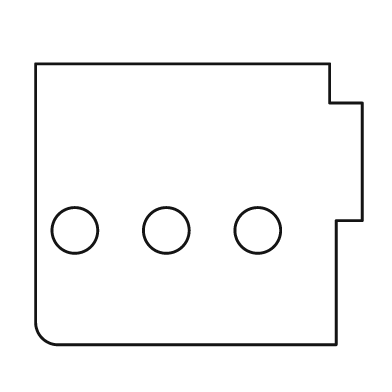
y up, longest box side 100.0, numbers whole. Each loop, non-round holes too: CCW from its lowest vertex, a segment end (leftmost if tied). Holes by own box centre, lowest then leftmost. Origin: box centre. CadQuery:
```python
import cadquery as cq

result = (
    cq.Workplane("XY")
    .moveTo(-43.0, -43.0)
    .lineTo(42.0, -43.0)
    .lineTo(42.0, -5.0)
    .lineTo(50.0, -5.0)
    .lineTo(50.0, 31.0)
    .lineTo(40.0, 31.0)
    .lineTo(40.0, 43.0)
    .lineTo(-50.0, 43.0)
    .lineTo(-50.0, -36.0)
    .threePointArc((-48.0, -41.0), (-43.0, -43.0))
    .close()
    .moveTo(-38.0, -8.0)
    .circle(7.0)
    .moveTo(-10.0, -8.0)
    .circle(7.0)
    .moveTo(18.0, -8.0)
    .circle(7.0)
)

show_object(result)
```